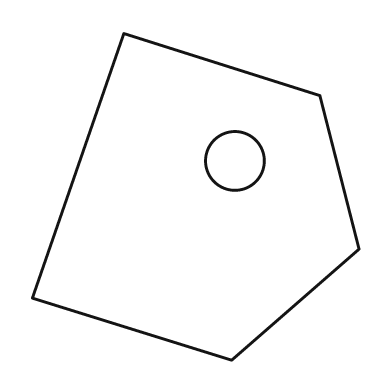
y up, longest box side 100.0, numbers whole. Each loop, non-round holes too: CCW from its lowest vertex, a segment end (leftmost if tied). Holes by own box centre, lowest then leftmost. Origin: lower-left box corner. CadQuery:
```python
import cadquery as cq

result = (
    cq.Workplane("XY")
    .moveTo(61.0, 0.0)
    .lineTo(100.0, 34.0)
    .lineTo(88.0, 81.0)
    .lineTo(28.0, 100.0)
    .lineTo(0.0, 19.0)
    .close()
    .moveTo(62.0, 61.0)
    .circle(9.0)
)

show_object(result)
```